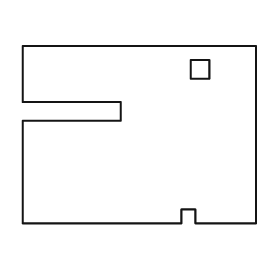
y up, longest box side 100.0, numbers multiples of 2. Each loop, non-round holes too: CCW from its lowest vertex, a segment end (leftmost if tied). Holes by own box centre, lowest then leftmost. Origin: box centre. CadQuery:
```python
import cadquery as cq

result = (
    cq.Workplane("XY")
    .moveTo(-50.0, -38.0)
    .lineTo(18.0, -38.0)
    .lineTo(18.0, -32.0)
    .lineTo(24.0, -32.0)
    .lineTo(24.0, -38.0)
    .lineTo(50.0, -38.0)
    .lineTo(50.0, 38.0)
    .lineTo(-50.0, 38.0)
    .lineTo(-50.0, 14.0)
    .lineTo(-8.0, 14.0)
    .lineTo(-8.0, 6.0)
    .lineTo(-50.0, 6.0)
    .close()
    .moveTo(22.0, 24.0)
    .lineTo(30.0, 24.0)
    .lineTo(30.0, 32.0)
    .lineTo(22.0, 32.0)
    .close()
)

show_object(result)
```